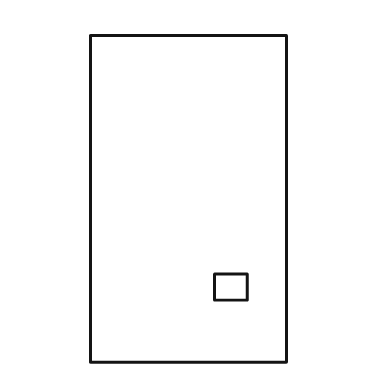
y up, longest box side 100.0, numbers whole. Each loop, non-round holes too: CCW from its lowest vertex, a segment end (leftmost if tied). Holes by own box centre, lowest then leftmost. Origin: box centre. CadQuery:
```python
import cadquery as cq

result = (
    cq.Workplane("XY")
    .moveTo(-30.0, -50.0)
    .lineTo(30.0, -50.0)
    .lineTo(30.0, 50.0)
    .lineTo(-30.0, 50.0)
    .close()
    .moveTo(8.0, -31.0)
    .lineTo(18.0, -31.0)
    .lineTo(18.0, -23.0)
    .lineTo(8.0, -23.0)
    .close()
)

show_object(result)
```